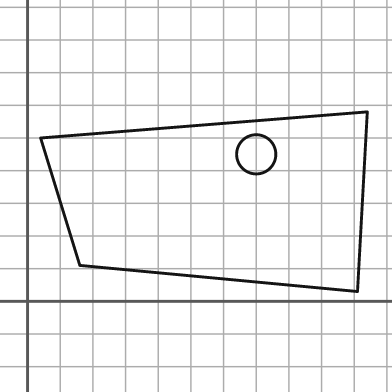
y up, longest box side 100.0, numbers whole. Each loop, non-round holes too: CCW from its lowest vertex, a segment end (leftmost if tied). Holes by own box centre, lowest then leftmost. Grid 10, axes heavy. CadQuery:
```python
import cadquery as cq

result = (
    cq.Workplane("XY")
    .moveTo(101.0, 3.0)
    .lineTo(104.0, 58.0)
    .lineTo(4.0, 50.0)
    .lineTo(16.0, 11.0)
    .close()
    .moveTo(70.0, 45.0)
    .circle(6.0)
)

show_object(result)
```